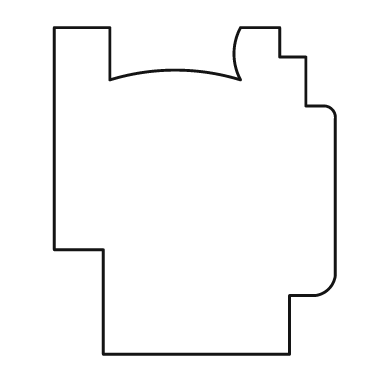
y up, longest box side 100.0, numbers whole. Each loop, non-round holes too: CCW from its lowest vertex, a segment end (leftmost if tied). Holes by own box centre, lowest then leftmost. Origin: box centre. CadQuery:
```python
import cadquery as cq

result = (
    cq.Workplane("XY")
    .moveTo(-28.0, -50.0)
    .lineTo(29.0, -50.0)
    .lineTo(29.0, -32.0)
    .lineTo(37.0, -32.0)
    .threePointArc((41.0, -30.0), (43.0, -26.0))
    .lineTo(43.0, 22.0)
    .threePointArc((42.0, 25.0), (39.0, 26.0))
    .lineTo(34.0, 26.0)
    .lineTo(34.0, 41.0)
    .lineTo(26.0, 41.0)
    .lineTo(26.0, 50.0)
    .lineTo(14.0, 50.0)
    .threePointArc((12.0, 42.0), (14.0, 34.0))
    .threePointArc((-6.0, 37.0), (-26.0, 34.0))
    .lineTo(-26.0, 50.0)
    .lineTo(-43.0, 50.0)
    .lineTo(-43.0, -18.0)
    .lineTo(-28.0, -18.0)
    .close()
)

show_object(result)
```